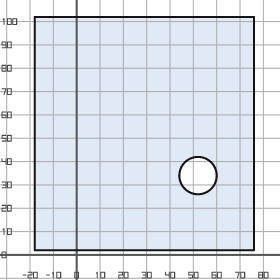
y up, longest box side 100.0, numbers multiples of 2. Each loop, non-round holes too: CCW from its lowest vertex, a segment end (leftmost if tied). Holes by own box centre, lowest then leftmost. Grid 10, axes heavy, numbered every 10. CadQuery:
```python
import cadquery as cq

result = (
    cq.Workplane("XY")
    .moveTo(-18.0, 2.0)
    .lineTo(76.0, 2.0)
    .lineTo(76.0, 102.0)
    .lineTo(-18.0, 102.0)
    .close()
    .moveTo(52.0, 34.0)
    .circle(8.0)
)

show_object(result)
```